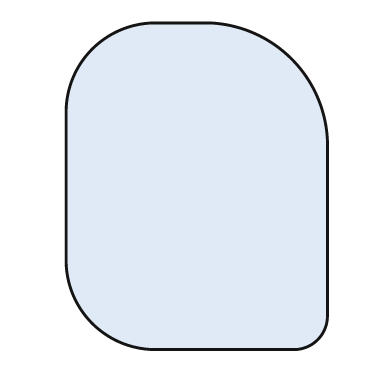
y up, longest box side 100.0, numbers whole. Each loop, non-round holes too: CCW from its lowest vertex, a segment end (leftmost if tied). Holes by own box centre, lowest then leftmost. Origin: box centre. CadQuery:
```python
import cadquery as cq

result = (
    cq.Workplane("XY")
    .moveTo(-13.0, -50.0)
    .lineTo(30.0, -50.0)
    .threePointArc((37.0, -47.0), (40.0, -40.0))
    .lineTo(40.0, 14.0)
    .threePointArc((29.0, 39.0), (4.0, 50.0))
    .lineTo(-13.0, 50.0)
    .threePointArc((-32.0, 42.0), (-40.0, 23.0))
    .lineTo(-40.0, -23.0)
    .threePointArc((-32.0, -42.0), (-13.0, -50.0))
    .close()
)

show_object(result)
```